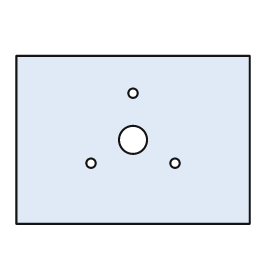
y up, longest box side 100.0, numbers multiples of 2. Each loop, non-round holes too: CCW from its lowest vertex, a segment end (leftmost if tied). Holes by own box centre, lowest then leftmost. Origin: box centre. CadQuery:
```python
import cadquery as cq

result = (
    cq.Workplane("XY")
    .moveTo(-50.0, -36.0)
    .lineTo(50.0, -36.0)
    .lineTo(50.0, 36.0)
    .lineTo(-50.0, 36.0)
    .close()
    .moveTo(-18.0, -10.0)
    .circle(2.0)
    .moveTo(18.0, -10.0)
    .circle(2.0)
    .moveTo(0.0, 0.0)
    .circle(6.0)
    .moveTo(0.0, 20.0)
    .circle(2.0)
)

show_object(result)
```